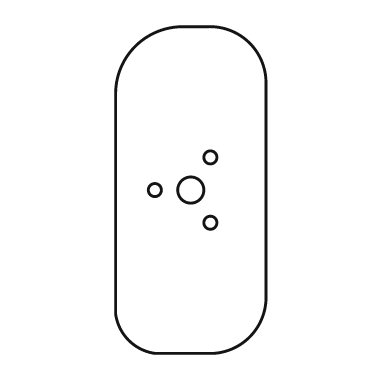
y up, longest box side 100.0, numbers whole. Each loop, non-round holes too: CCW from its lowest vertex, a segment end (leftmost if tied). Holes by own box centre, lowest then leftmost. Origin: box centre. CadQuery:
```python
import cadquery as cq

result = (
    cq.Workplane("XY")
    .moveTo(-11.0, -50.0)
    .lineTo(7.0, -50.0)
    .threePointArc((18.0, -45.0), (23.0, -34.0))
    .lineTo(23.0, 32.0)
    .threePointArc((18.0, 45.0), (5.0, 50.0))
    .lineTo(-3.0, 50.0)
    .threePointArc((-17.0, 44.0), (-23.0, 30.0))
    .lineTo(-23.0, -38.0)
    .threePointArc((-19.0, -46.0), (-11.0, -50.0))
    .close()
    .moveTo(6.0, -10.0)
    .circle(2.0)
    .moveTo(-11.0, 0.0)
    .circle(2.0)
    .moveTo(0.0, 0.0)
    .circle(4.0)
    .moveTo(6.0, 10.0)
    .circle(2.0)
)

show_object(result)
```